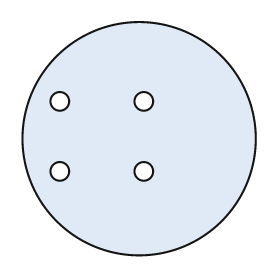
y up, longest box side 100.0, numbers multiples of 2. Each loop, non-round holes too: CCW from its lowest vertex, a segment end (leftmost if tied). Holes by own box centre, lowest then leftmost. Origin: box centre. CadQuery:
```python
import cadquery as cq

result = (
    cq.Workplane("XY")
    .moveTo(0.0, 0.0)
    .circle(50.0)
    .moveTo(-34.0, -14.0)
    .circle(4.0)
    .moveTo(2.0, -14.0)
    .circle(4.0)
    .moveTo(-34.0, 16.0)
    .circle(4.0)
    .moveTo(2.0, 16.0)
    .circle(4.0)
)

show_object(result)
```